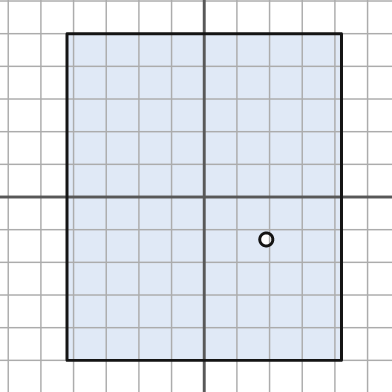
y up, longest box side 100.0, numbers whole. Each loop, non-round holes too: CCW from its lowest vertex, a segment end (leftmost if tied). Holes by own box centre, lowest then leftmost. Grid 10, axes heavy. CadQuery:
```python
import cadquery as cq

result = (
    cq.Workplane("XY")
    .moveTo(-42.0, -50.0)
    .lineTo(42.0, -50.0)
    .lineTo(42.0, 50.0)
    .lineTo(-42.0, 50.0)
    .close()
    .moveTo(19.0, -13.0)
    .circle(2.0)
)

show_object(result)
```